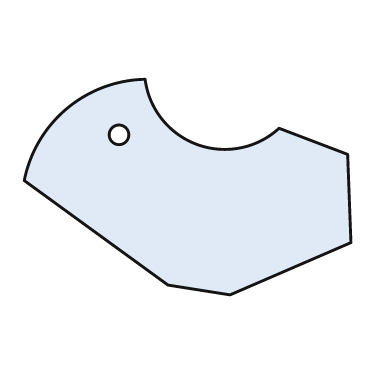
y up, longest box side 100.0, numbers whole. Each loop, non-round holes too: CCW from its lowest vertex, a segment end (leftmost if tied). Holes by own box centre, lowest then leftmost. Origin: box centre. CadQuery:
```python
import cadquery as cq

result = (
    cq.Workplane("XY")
    .moveTo(13.0, -33.0)
    .lineTo(50.0, -17.0)
    .lineTo(49.0, 10.0)
    .lineTo(28.0, 18.0)
    .threePointArc((3.0, 13.0), (-13.0, 33.0))
    .threePointArc((-37.0, 24.0), (-50.0, 2.0))
    .lineTo(-6.0, -30.0)
    .close()
    .moveTo(-21.0, 16.0)
    .circle(3.0)
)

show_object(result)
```